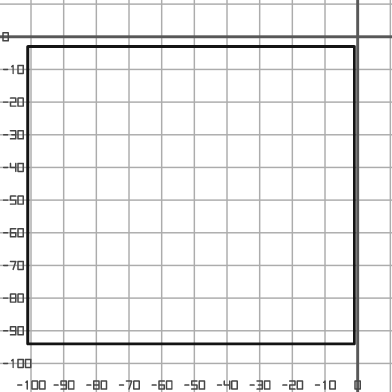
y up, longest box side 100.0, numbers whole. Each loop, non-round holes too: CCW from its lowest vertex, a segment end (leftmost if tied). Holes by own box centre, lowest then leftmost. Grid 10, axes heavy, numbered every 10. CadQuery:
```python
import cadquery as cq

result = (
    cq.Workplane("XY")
    .moveTo(-101.0, -94.0)
    .lineTo(-1.0, -94.0)
    .lineTo(-1.0, -3.0)
    .lineTo(-101.0, -3.0)
    .close()
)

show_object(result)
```